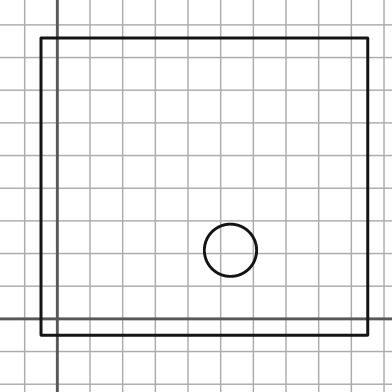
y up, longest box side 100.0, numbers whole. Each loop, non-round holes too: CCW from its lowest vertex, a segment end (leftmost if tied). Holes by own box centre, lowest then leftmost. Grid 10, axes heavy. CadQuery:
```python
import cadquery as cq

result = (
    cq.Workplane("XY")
    .moveTo(-5.0, -5.0)
    .lineTo(95.0, -5.0)
    .lineTo(95.0, 86.0)
    .lineTo(-5.0, 86.0)
    .close()
    .moveTo(53.0, 21.0)
    .circle(8.0)
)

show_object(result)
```